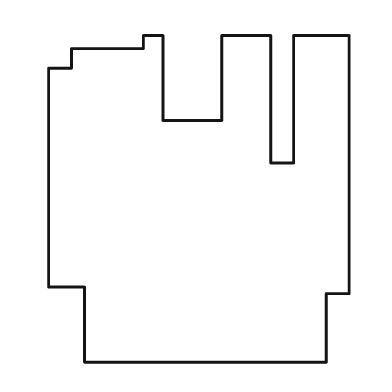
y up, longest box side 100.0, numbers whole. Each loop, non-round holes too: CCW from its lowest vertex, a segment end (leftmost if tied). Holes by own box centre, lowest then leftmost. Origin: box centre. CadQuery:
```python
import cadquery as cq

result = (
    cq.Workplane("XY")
    .moveTo(-35.0, -50.0)
    .lineTo(39.0, -50.0)
    .lineTo(39.0, -29.0)
    .lineTo(46.0, -29.0)
    .lineTo(46.0, 50.0)
    .lineTo(29.0, 50.0)
    .lineTo(29.0, 11.0)
    .lineTo(22.0, 11.0)
    .lineTo(22.0, 50.0)
    .lineTo(7.0, 50.0)
    .lineTo(7.0, 24.0)
    .lineTo(-11.0, 24.0)
    .lineTo(-11.0, 50.0)
    .lineTo(-17.0, 50.0)
    .lineTo(-17.0, 46.0)
    .lineTo(-39.0, 46.0)
    .lineTo(-39.0, 40.0)
    .lineTo(-46.0, 40.0)
    .lineTo(-46.0, -27.0)
    .lineTo(-35.0, -27.0)
    .close()
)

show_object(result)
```